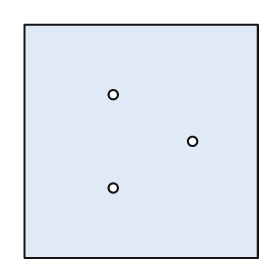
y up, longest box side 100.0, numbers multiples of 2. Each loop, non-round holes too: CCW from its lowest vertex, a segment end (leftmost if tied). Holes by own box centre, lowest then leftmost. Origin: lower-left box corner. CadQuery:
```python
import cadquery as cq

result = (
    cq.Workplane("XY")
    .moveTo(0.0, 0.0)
    .lineTo(100.0, 0.0)
    .lineTo(100.0, 100.0)
    .lineTo(0.0, 100.0)
    .close()
    .moveTo(38.0, 30.0)
    .circle(2.0)
    .moveTo(72.0, 50.0)
    .circle(2.0)
    .moveTo(38.0, 70.0)
    .circle(2.0)
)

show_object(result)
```